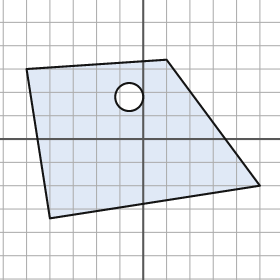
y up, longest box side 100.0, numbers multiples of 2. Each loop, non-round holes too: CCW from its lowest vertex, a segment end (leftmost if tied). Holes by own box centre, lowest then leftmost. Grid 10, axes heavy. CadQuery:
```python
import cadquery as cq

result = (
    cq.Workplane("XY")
    .moveTo(-40.0, -34.0)
    .lineTo(50.0, -20.0)
    .lineTo(10.0, 34.0)
    .lineTo(-50.0, 30.0)
    .close()
    .moveTo(-6.0, 18.0)
    .circle(6.0)
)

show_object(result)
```